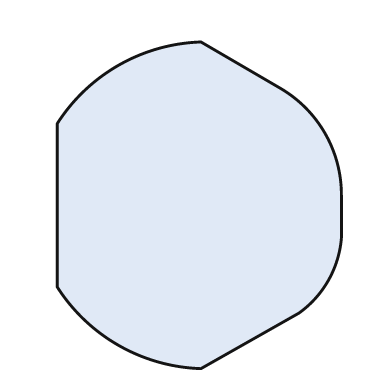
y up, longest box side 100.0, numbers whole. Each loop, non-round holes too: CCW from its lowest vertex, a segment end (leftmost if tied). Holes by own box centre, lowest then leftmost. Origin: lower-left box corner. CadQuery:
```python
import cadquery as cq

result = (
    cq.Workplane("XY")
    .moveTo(44.0, 0.0)
    .lineTo(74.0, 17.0)
    .threePointArc((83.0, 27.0), (87.0, 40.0))
    .lineTo(87.0, 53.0)
    .threePointArc((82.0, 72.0), (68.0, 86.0))
    .lineTo(44.0, 100.0)
    .threePointArc((19.0, 93.0), (0.0, 75.0))
    .lineTo(0.0, 25.0)
    .threePointArc((19.0, 7.0), (44.0, 0.0))
    .close()
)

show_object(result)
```